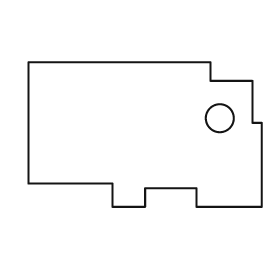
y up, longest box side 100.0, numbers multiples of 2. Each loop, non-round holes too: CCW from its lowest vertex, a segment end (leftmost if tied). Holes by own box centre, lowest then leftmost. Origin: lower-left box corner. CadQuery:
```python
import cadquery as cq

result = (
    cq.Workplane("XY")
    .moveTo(36.0, 0.0)
    .lineTo(50.0, 0.0)
    .lineTo(50.0, 8.0)
    .lineTo(72.0, 8.0)
    .lineTo(72.0, 0.0)
    .lineTo(100.0, 0.0)
    .lineTo(100.0, 36.0)
    .lineTo(96.0, 36.0)
    .lineTo(96.0, 54.0)
    .lineTo(78.0, 54.0)
    .lineTo(78.0, 62.0)
    .lineTo(0.0, 62.0)
    .lineTo(0.0, 10.0)
    .lineTo(36.0, 10.0)
    .close()
    .moveTo(82.0, 38.0)
    .circle(6.0)
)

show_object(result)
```